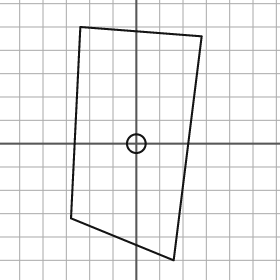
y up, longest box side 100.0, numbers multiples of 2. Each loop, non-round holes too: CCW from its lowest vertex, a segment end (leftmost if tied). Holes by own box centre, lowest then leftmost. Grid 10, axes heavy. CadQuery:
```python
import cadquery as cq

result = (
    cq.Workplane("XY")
    .moveTo(16.0, -50.0)
    .lineTo(28.0, 46.0)
    .lineTo(-24.0, 50.0)
    .lineTo(-28.0, -32.0)
    .close()
    .moveTo(0.0, 0.0)
    .circle(4.0)
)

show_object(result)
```